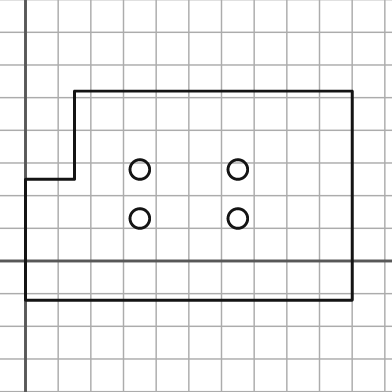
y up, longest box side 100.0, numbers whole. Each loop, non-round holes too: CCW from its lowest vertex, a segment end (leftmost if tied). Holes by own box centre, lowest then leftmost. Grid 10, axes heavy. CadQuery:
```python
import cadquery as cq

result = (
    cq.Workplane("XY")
    .moveTo(0.0, -12.0)
    .lineTo(100.0, -12.0)
    .lineTo(100.0, 52.0)
    .lineTo(15.0, 52.0)
    .lineTo(15.0, 25.0)
    .lineTo(0.0, 25.0)
    .close()
    .moveTo(35.0, 13.0)
    .circle(3.0)
    .moveTo(65.0, 13.0)
    .circle(3.0)
    .moveTo(35.0, 28.0)
    .circle(3.0)
    .moveTo(65.0, 28.0)
    .circle(3.0)
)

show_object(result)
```